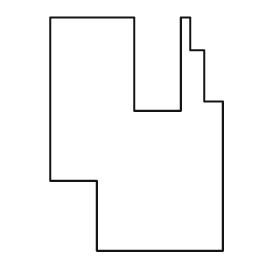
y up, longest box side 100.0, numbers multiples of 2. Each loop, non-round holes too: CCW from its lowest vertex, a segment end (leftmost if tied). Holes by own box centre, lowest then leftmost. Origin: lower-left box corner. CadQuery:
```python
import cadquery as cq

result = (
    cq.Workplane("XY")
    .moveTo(20.0, 0.0)
    .lineTo(74.0, 0.0)
    .lineTo(74.0, 64.0)
    .lineTo(66.0, 64.0)
    .lineTo(66.0, 86.0)
    .lineTo(60.0, 86.0)
    .lineTo(60.0, 100.0)
    .lineTo(56.0, 100.0)
    .lineTo(56.0, 60.0)
    .lineTo(36.0, 60.0)
    .lineTo(36.0, 100.0)
    .lineTo(0.0, 100.0)
    .lineTo(0.0, 30.0)
    .lineTo(20.0, 30.0)
    .close()
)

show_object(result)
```